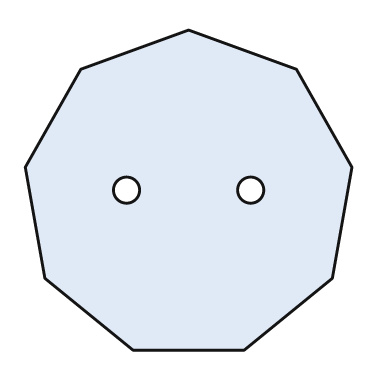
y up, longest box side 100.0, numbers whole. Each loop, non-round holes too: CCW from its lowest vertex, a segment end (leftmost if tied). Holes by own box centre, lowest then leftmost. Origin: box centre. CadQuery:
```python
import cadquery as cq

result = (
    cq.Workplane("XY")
    .moveTo(-17.0, -49.0)
    .lineTo(17.0, -49.0)
    .lineTo(44.0, -27.0)
    .lineTo(50.0, 7.0)
    .lineTo(33.0, 37.0)
    .lineTo(0.0, 49.0)
    .lineTo(-33.0, 37.0)
    .lineTo(-50.0, 7.0)
    .lineTo(-44.0, -27.0)
    .close()
    .moveTo(-19.0, 0.0)
    .circle(4.0)
    .moveTo(19.0, 0.0)
    .circle(4.0)
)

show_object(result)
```